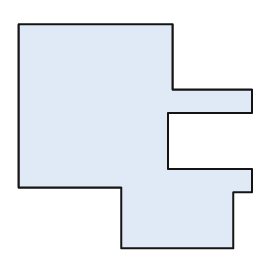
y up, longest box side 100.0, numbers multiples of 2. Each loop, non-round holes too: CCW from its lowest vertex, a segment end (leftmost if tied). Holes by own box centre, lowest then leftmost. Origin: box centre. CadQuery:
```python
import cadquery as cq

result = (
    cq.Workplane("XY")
    .moveTo(-6.0, -48.0)
    .lineTo(42.0, -48.0)
    .lineTo(42.0, -24.0)
    .lineTo(50.0, -24.0)
    .lineTo(50.0, -14.0)
    .lineTo(14.0, -14.0)
    .lineTo(14.0, 10.0)
    .lineTo(50.0, 10.0)
    .lineTo(50.0, 20.0)
    .lineTo(16.0, 20.0)
    .lineTo(16.0, 48.0)
    .lineTo(-50.0, 48.0)
    .lineTo(-50.0, -22.0)
    .lineTo(-6.0, -22.0)
    .close()
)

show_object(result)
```